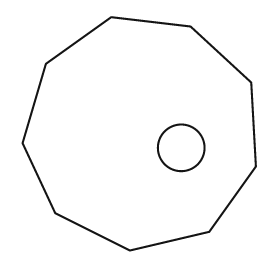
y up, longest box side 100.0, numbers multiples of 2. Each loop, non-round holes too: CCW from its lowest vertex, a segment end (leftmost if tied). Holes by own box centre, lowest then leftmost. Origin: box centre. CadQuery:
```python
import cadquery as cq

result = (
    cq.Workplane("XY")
    .moveTo(-4.0, -50.0)
    .lineTo(30.0, -42.0)
    .lineTo(50.0, -14.0)
    .lineTo(48.0, 22.0)
    .lineTo(22.0, 46.0)
    .lineTo(-12.0, 50.0)
    .lineTo(-40.0, 30.0)
    .lineTo(-50.0, -4.0)
    .lineTo(-36.0, -34.0)
    .close()
    .moveTo(18.0, -6.0)
    .circle(10.0)
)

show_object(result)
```